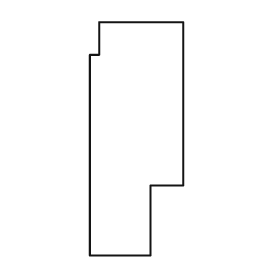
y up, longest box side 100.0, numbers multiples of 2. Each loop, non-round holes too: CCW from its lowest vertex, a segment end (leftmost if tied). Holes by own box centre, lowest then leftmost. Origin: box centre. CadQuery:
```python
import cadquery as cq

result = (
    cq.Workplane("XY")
    .moveTo(-20.0, -50.0)
    .lineTo(6.0, -50.0)
    .lineTo(6.0, -20.0)
    .lineTo(20.0, -20.0)
    .lineTo(20.0, 50.0)
    .lineTo(-16.0, 50.0)
    .lineTo(-16.0, 36.0)
    .lineTo(-20.0, 36.0)
    .close()
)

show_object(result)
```